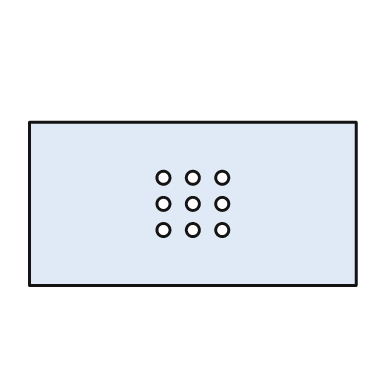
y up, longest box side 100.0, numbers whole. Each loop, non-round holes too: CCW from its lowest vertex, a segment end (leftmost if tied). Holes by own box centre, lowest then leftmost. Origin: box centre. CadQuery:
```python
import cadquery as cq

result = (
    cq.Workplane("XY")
    .moveTo(-50.0, -25.0)
    .lineTo(50.0, -25.0)
    .lineTo(50.0, 25.0)
    .lineTo(-50.0, 25.0)
    .close()
    .moveTo(-9.0, -8.0)
    .circle(2.0)
    .moveTo(0.0, -8.0)
    .circle(2.0)
    .moveTo(9.0, -8.0)
    .circle(2.0)
    .moveTo(-9.0, 0.0)
    .circle(2.0)
    .moveTo(0.0, 0.0)
    .circle(2.0)
    .moveTo(9.0, 0.0)
    .circle(2.0)
    .moveTo(-9.0, 8.0)
    .circle(2.0)
    .moveTo(0.0, 8.0)
    .circle(2.0)
    .moveTo(9.0, 8.0)
    .circle(2.0)
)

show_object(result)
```